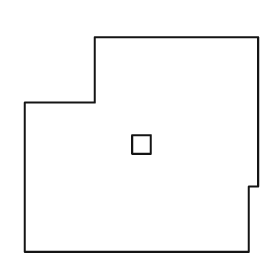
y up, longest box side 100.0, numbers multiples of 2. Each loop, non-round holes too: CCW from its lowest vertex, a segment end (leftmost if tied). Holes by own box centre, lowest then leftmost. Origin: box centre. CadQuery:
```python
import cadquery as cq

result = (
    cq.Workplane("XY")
    .moveTo(-50.0, -46.0)
    .lineTo(46.0, -46.0)
    .lineTo(46.0, -18.0)
    .lineTo(50.0, -18.0)
    .lineTo(50.0, 46.0)
    .lineTo(-20.0, 46.0)
    .lineTo(-20.0, 18.0)
    .lineTo(-50.0, 18.0)
    .close()
    .moveTo(-4.0, -4.0)
    .lineTo(4.0, -4.0)
    .lineTo(4.0, 4.0)
    .lineTo(-4.0, 4.0)
    .close()
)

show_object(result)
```